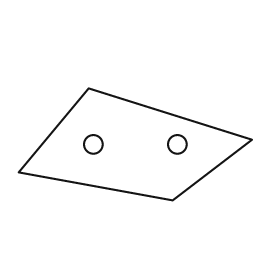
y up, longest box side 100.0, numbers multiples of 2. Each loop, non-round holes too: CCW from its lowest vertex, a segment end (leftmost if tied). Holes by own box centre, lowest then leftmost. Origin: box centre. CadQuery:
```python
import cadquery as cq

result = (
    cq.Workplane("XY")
    .moveTo(16.0, -24.0)
    .lineTo(50.0, 2.0)
    .lineTo(-20.0, 24.0)
    .lineTo(-50.0, -12.0)
    .close()
    .moveTo(-18.0, 0.0)
    .circle(4.0)
    .moveTo(18.0, 0.0)
    .circle(4.0)
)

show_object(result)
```